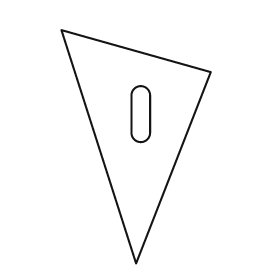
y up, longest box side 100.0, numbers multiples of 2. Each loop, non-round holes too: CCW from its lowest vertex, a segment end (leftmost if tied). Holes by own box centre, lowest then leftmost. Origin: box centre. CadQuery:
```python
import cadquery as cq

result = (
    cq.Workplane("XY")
    .moveTo(0.0, -50.0)
    .lineTo(32.0, 32.0)
    .lineTo(-32.0, 50.0)
    .close()
    .moveTo(-2.0, 6.0)
    .threePointArc((2.0, 2.0), (6.0, 6.0))
    .lineTo(6.0, 22.0)
    .threePointArc((2.0, 26.0), (-2.0, 22.0))
    .close()
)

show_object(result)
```